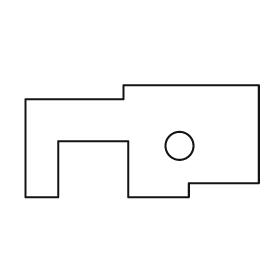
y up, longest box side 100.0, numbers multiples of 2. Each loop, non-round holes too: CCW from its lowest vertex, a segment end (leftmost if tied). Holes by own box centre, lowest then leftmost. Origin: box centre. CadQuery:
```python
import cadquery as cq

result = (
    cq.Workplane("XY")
    .moveTo(-50.0, -24.0)
    .lineTo(-36.0, -24.0)
    .lineTo(-36.0, 0.0)
    .lineTo(-6.0, 0.0)
    .lineTo(-6.0, -24.0)
    .lineTo(20.0, -24.0)
    .lineTo(20.0, -18.0)
    .lineTo(50.0, -18.0)
    .lineTo(50.0, 24.0)
    .lineTo(-8.0, 24.0)
    .lineTo(-8.0, 18.0)
    .lineTo(-50.0, 18.0)
    .close()
    .moveTo(16.0, -2.0)
    .circle(6.0)
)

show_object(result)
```